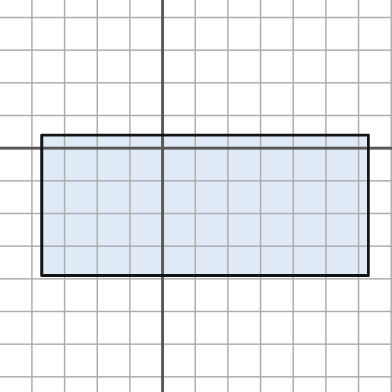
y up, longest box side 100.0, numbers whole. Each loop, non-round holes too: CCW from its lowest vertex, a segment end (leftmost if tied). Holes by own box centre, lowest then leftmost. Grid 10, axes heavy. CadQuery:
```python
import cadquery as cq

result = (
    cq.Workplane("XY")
    .moveTo(-37.0, -39.0)
    .lineTo(63.0, -39.0)
    .lineTo(63.0, 4.0)
    .lineTo(-37.0, 4.0)
    .close()
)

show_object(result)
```